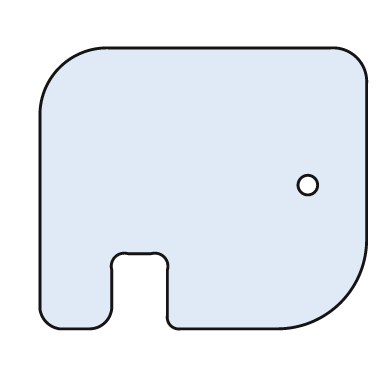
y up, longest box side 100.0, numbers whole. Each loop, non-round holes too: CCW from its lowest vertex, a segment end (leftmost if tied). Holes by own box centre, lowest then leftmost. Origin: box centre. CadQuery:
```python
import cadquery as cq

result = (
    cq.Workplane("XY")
    .moveTo(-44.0, -43.0)
    .lineTo(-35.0, -43.0)
    .threePointArc((-30.0, -41.0), (-28.0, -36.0))
    .lineTo(-28.0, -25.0)
    .threePointArc((-27.0, -21.0), (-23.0, -20.0))
    .lineTo(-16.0, -20.0)
    .threePointArc((-12.0, -21.0), (-11.0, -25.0))
    .lineTo(-11.0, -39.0)
    .threePointArc((-10.0, -42.0), (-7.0, -43.0))
    .lineTo(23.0, -43.0)
    .threePointArc((42.0, -35.0), (50.0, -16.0))
    .lineTo(50.0, 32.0)
    .threePointArc((47.0, 40.0), (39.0, 43.0))
    .lineTo(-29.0, 43.0)
    .threePointArc((-44.0, 37.0), (-50.0, 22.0))
    .lineTo(-50.0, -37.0)
    .threePointArc((-48.0, -41.0), (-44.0, -43.0))
    .close()
    .moveTo(32.0, 1.0)
    .circle(3.0)
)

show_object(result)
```